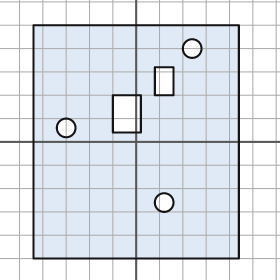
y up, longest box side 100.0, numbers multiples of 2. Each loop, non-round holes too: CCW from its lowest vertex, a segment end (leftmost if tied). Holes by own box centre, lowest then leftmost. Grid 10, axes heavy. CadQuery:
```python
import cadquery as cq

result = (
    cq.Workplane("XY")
    .moveTo(-44.0, -50.0)
    .lineTo(44.0, -50.0)
    .lineTo(44.0, 50.0)
    .lineTo(-44.0, 50.0)
    .close()
    .moveTo(12.0, -26.0)
    .circle(4.0)
    .moveTo(-30.0, 6.0)
    .circle(4.0)
    .moveTo(-10.0, 4.0)
    .lineTo(2.0, 4.0)
    .lineTo(2.0, 20.0)
    .lineTo(-10.0, 20.0)
    .close()
    .moveTo(8.0, 20.0)
    .lineTo(16.0, 20.0)
    .lineTo(16.0, 32.0)
    .lineTo(8.0, 32.0)
    .close()
    .moveTo(24.0, 40.0)
    .circle(4.0)
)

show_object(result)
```